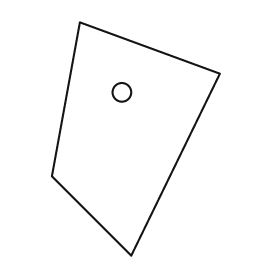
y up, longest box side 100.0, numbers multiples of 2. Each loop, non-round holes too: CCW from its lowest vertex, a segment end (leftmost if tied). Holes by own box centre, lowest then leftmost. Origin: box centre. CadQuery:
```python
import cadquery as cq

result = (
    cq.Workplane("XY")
    .moveTo(-2.0, -50.0)
    .lineTo(36.0, 28.0)
    .lineTo(-24.0, 50.0)
    .lineTo(-36.0, -16.0)
    .close()
    .moveTo(-6.0, 20.0)
    .circle(4.0)
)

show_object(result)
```